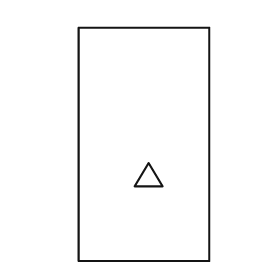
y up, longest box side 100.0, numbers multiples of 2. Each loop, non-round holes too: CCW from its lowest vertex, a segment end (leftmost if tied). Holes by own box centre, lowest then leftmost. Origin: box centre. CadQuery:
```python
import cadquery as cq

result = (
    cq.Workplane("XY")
    .moveTo(-28.0, -50.0)
    .lineTo(28.0, -50.0)
    .lineTo(28.0, 50.0)
    .lineTo(-28.0, 50.0)
    .close()
    .moveTo(-4.0, -18.0)
    .lineTo(8.0, -18.0)
    .lineTo(2.0, -8.0)
    .close()
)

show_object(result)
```